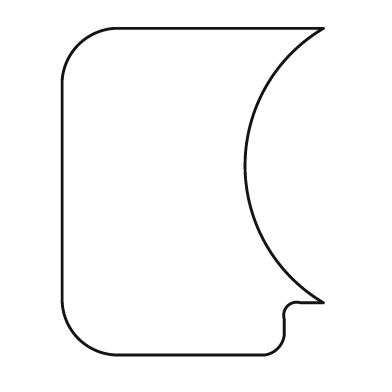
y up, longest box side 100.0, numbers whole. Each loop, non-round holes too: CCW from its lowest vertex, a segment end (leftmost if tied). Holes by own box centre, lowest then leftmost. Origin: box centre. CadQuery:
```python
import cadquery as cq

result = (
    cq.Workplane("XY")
    .moveTo(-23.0, -50.0)
    .lineTo(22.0, -50.0)
    .threePointArc((26.0, -48.0), (28.0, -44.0))
    .lineTo(28.0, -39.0)
    .threePointArc((29.0, -35.0), (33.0, -34.0))
    .lineTo(40.0, -34.0)
    .threePointArc((16.0, 8.0), (40.0, 50.0))
    .lineTo(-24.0, 50.0)
    .threePointArc((-35.0, 45.0), (-40.0, 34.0))
    .lineTo(-40.0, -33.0)
    .threePointArc((-35.0, -45.0), (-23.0, -50.0))
    .close()
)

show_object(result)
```